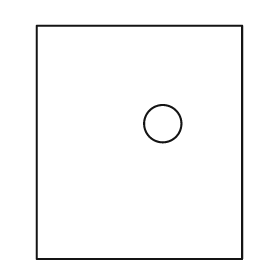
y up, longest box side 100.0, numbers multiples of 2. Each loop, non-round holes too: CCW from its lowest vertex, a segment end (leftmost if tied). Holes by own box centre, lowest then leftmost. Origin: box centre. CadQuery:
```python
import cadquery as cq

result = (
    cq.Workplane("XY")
    .moveTo(-44.0, -50.0)
    .lineTo(44.0, -50.0)
    .lineTo(44.0, 50.0)
    .lineTo(-44.0, 50.0)
    .close()
    .moveTo(10.0, 8.0)
    .circle(8.0)
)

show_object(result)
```